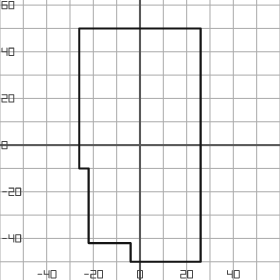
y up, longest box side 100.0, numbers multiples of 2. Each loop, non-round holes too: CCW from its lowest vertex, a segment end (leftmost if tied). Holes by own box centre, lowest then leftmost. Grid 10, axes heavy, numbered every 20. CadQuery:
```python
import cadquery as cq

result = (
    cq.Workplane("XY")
    .moveTo(-4.0, -50.0)
    .lineTo(26.0, -50.0)
    .lineTo(26.0, 50.0)
    .lineTo(-26.0, 50.0)
    .lineTo(-26.0, -10.0)
    .lineTo(-22.0, -10.0)
    .lineTo(-22.0, -42.0)
    .lineTo(-4.0, -42.0)
    .close()
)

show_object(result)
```